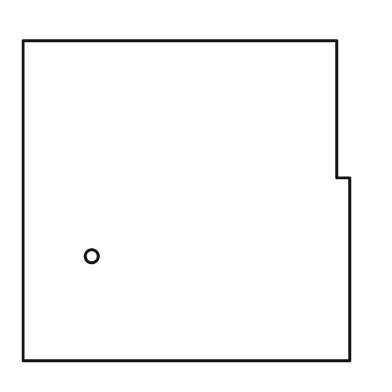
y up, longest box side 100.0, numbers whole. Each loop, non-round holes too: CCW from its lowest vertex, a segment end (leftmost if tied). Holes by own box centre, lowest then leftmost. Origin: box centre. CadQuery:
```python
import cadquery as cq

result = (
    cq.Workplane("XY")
    .moveTo(-50.0, -49.0)
    .lineTo(50.0, -49.0)
    .lineTo(50.0, 7.0)
    .lineTo(46.0, 7.0)
    .lineTo(46.0, 49.0)
    .lineTo(-50.0, 49.0)
    .close()
    .moveTo(-29.0, -17.0)
    .circle(2.0)
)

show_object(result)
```